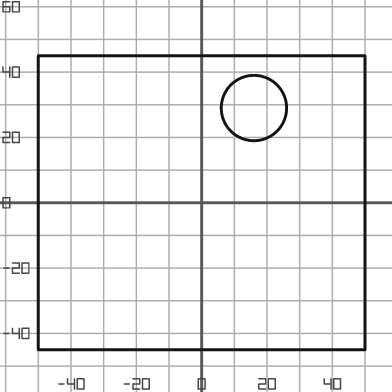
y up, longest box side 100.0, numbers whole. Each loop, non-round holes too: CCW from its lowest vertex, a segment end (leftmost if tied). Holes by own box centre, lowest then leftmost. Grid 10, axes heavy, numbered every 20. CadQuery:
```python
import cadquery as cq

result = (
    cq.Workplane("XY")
    .moveTo(-50.0, -45.0)
    .lineTo(50.0, -45.0)
    .lineTo(50.0, 45.0)
    .lineTo(-50.0, 45.0)
    .close()
    .moveTo(16.0, 29.0)
    .circle(10.0)
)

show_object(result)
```